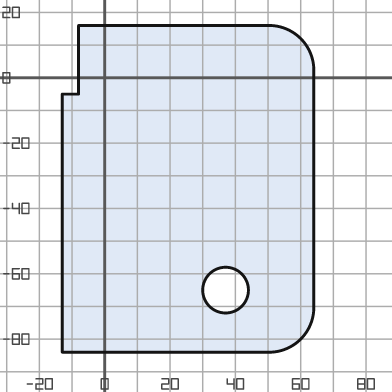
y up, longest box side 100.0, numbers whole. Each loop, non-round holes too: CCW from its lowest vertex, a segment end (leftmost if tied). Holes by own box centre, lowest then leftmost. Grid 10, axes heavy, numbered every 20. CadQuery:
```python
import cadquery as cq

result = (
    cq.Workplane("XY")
    .moveTo(-13.0, -84.0)
    .lineTo(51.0, -84.0)
    .threePointArc((60.0, -80.0), (64.0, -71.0))
    .lineTo(64.0, 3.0)
    .threePointArc((60.0, 12.0), (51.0, 16.0))
    .lineTo(-8.0, 16.0)
    .lineTo(-8.0, -5.0)
    .lineTo(-13.0, -5.0)
    .close()
    .moveTo(37.0, -65.0)
    .circle(7.0)
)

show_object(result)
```